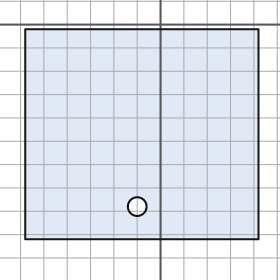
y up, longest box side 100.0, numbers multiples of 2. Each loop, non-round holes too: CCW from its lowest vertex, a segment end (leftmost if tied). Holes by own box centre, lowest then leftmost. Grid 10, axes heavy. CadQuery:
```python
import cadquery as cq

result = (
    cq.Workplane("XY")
    .moveTo(-58.0, -92.0)
    .lineTo(42.0, -92.0)
    .lineTo(42.0, -2.0)
    .lineTo(-58.0, -2.0)
    .close()
    .moveTo(-10.0, -78.0)
    .circle(4.0)
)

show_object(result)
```